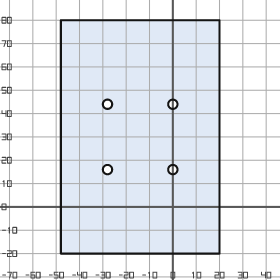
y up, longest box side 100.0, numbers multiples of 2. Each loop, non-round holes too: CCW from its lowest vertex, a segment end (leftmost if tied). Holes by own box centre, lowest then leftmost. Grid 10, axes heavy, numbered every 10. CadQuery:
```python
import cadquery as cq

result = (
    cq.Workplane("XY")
    .moveTo(-48.0, -20.0)
    .lineTo(20.0, -20.0)
    .lineTo(20.0, 80.0)
    .lineTo(-48.0, 80.0)
    .close()
    .moveTo(-28.0, 16.0)
    .circle(2.0)
    .moveTo(0.0, 16.0)
    .circle(2.0)
    .moveTo(-28.0, 44.0)
    .circle(2.0)
    .moveTo(0.0, 44.0)
    .circle(2.0)
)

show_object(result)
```